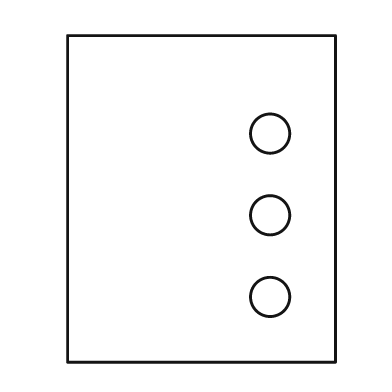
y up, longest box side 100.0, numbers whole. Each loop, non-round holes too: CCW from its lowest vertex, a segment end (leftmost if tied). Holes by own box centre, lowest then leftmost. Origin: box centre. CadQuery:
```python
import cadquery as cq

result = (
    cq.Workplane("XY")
    .moveTo(-41.0, -50.0)
    .lineTo(41.0, -50.0)
    .lineTo(41.0, 50.0)
    .lineTo(-41.0, 50.0)
    .close()
    .moveTo(21.0, -30.0)
    .circle(6.0)
    .moveTo(21.0, -5.0)
    .circle(6.0)
    .moveTo(21.0, 20.0)
    .circle(6.0)
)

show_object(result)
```